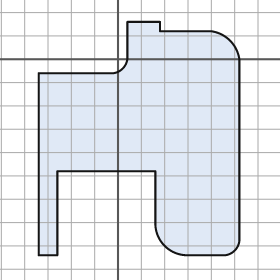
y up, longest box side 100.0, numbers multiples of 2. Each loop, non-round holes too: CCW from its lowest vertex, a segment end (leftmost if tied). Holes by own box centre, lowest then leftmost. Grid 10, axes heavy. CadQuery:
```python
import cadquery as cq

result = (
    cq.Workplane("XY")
    .moveTo(-34.0, -84.0)
    .lineTo(-26.0, -84.0)
    .lineTo(-26.0, -48.0)
    .lineTo(16.0, -48.0)
    .lineTo(16.0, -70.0)
    .threePointArc((20.0, -80.0), (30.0, -84.0))
    .lineTo(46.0, -84.0)
    .threePointArc((50.0, -82.0), (52.0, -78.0))
    .lineTo(52.0, 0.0)
    .threePointArc((48.0, 8.0), (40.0, 12.0))
    .lineTo(18.0, 12.0)
    .lineTo(18.0, 16.0)
    .lineTo(4.0, 16.0)
    .lineTo(4.0, 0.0)
    .threePointArc((2.0, -4.0), (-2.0, -6.0))
    .lineTo(-34.0, -6.0)
    .close()
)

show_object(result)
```